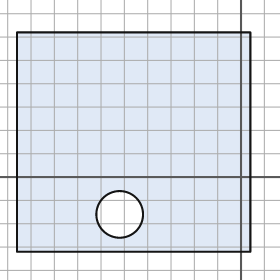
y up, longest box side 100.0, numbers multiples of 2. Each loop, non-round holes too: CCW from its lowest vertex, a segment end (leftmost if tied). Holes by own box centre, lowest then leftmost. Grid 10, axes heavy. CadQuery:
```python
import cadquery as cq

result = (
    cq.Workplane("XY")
    .moveTo(-96.0, -32.0)
    .lineTo(4.0, -32.0)
    .lineTo(4.0, 62.0)
    .lineTo(-96.0, 62.0)
    .close()
    .moveTo(-52.0, -16.0)
    .circle(10.0)
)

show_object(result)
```